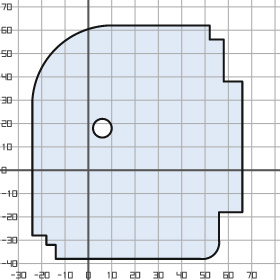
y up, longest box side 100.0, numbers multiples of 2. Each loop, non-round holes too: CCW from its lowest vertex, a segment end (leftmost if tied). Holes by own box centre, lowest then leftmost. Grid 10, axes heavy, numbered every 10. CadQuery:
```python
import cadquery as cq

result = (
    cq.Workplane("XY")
    .moveTo(-14.0, -38.0)
    .lineTo(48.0, -38.0)
    .threePointArc((54.0, -36.0), (56.0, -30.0))
    .lineTo(56.0, -18.0)
    .lineTo(66.0, -18.0)
    .lineTo(66.0, 38.0)
    .lineTo(58.0, 38.0)
    .lineTo(58.0, 56.0)
    .lineTo(52.0, 56.0)
    .lineTo(52.0, 62.0)
    .lineTo(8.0, 62.0)
    .threePointArc((-14.0, 52.0), (-24.0, 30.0))
    .lineTo(-24.0, -28.0)
    .lineTo(-18.0, -28.0)
    .lineTo(-18.0, -32.0)
    .lineTo(-14.0, -32.0)
    .close()
    .moveTo(6.0, 18.0)
    .circle(4.0)
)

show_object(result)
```